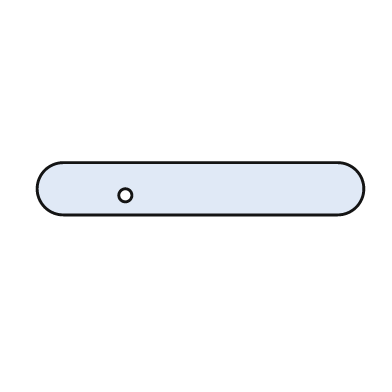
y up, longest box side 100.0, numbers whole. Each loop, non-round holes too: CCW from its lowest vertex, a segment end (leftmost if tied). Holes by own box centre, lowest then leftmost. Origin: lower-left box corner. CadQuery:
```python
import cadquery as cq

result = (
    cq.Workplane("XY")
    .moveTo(8.0, 0.0)
    .lineTo(92.0, 0.0)
    .threePointArc((100.0, 8.0), (92.0, 16.0))
    .lineTo(8.0, 16.0)
    .threePointArc((0.0, 8.0), (8.0, 0.0))
    .close()
    .moveTo(27.0, 6.0)
    .circle(2.0)
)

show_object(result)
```